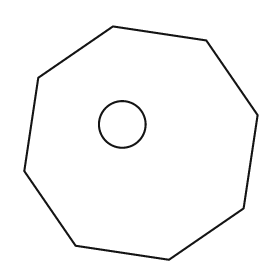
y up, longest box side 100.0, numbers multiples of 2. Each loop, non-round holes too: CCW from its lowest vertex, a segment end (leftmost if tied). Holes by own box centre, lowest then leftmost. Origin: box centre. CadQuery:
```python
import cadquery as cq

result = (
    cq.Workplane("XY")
    .moveTo(12.0, -50.0)
    .lineTo(44.0, -28.0)
    .lineTo(50.0, 12.0)
    .lineTo(28.0, 44.0)
    .lineTo(-12.0, 50.0)
    .lineTo(-44.0, 28.0)
    .lineTo(-50.0, -12.0)
    .lineTo(-28.0, -44.0)
    .close()
    .moveTo(-8.0, 8.0)
    .circle(10.0)
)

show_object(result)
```